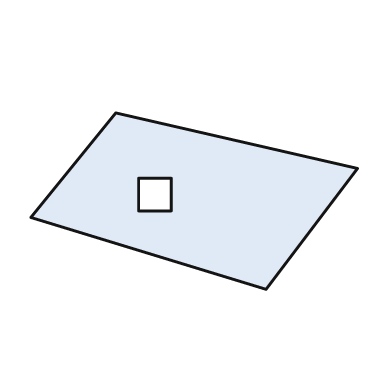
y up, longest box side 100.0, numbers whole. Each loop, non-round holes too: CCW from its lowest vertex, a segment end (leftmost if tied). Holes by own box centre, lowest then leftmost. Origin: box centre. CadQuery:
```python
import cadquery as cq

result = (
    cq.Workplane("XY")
    .moveTo(22.0, -27.0)
    .lineTo(50.0, 10.0)
    .lineTo(-24.0, 27.0)
    .lineTo(-50.0, -5.0)
    .close()
    .moveTo(-17.0, -3.0)
    .lineTo(-7.0, -3.0)
    .lineTo(-7.0, 7.0)
    .lineTo(-17.0, 7.0)
    .close()
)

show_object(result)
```